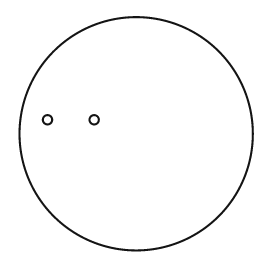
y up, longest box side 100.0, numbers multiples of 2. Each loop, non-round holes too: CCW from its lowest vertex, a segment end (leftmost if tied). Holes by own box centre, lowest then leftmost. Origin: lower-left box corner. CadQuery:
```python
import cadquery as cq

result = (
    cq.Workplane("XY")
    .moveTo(50.0, 50.0)
    .circle(50.0)
    .moveTo(12.0, 56.0)
    .circle(2.0)
    .moveTo(32.0, 56.0)
    .circle(2.0)
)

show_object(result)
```